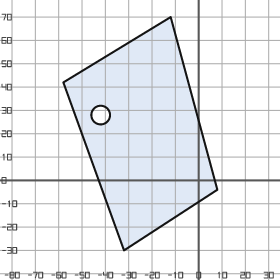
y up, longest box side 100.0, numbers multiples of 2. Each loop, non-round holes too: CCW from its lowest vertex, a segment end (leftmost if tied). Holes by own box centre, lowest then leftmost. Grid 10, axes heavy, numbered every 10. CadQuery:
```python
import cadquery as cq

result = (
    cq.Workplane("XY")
    .moveTo(-32.0, -30.0)
    .lineTo(8.0, -4.0)
    .lineTo(-12.0, 70.0)
    .lineTo(-58.0, 42.0)
    .close()
    .moveTo(-42.0, 28.0)
    .circle(4.0)
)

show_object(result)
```